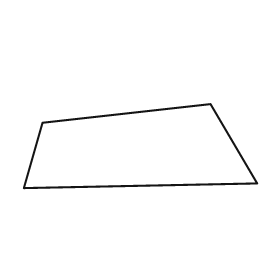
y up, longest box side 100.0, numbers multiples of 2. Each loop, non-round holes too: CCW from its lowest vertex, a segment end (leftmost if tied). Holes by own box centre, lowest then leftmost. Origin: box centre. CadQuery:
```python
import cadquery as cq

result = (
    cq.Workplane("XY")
    .moveTo(-50.0, -18.0)
    .lineTo(50.0, -16.0)
    .lineTo(30.0, 18.0)
    .lineTo(-42.0, 10.0)
    .close()
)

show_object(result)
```